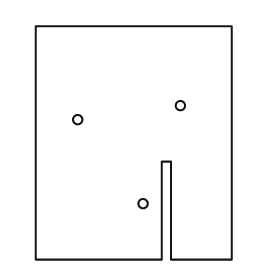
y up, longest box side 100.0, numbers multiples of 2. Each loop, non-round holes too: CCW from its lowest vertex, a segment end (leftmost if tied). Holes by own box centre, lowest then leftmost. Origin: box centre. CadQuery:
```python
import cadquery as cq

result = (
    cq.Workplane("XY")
    .moveTo(-42.0, -50.0)
    .lineTo(12.0, -50.0)
    .lineTo(12.0, -8.0)
    .lineTo(16.0, -8.0)
    .lineTo(16.0, -50.0)
    .lineTo(42.0, -50.0)
    .lineTo(42.0, 50.0)
    .lineTo(-42.0, 50.0)
    .close()
    .moveTo(4.0, -26.0)
    .circle(2.0)
    .moveTo(-24.0, 10.0)
    .circle(2.0)
    .moveTo(20.0, 16.0)
    .circle(2.0)
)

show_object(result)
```